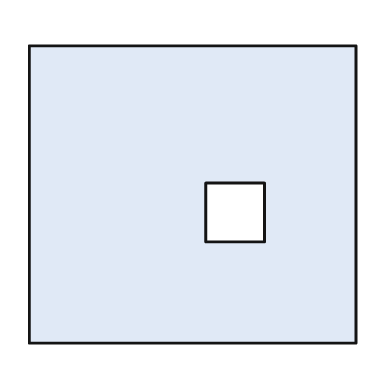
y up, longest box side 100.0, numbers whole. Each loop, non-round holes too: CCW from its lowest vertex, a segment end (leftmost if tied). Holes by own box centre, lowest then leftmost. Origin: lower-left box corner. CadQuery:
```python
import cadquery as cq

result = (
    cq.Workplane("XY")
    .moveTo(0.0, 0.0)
    .lineTo(100.0, 0.0)
    .lineTo(100.0, 91.0)
    .lineTo(0.0, 91.0)
    .close()
    .moveTo(54.0, 31.0)
    .lineTo(72.0, 31.0)
    .lineTo(72.0, 49.0)
    .lineTo(54.0, 49.0)
    .close()
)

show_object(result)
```